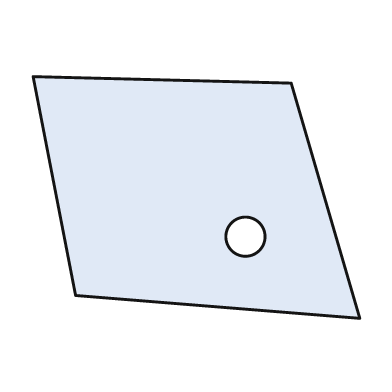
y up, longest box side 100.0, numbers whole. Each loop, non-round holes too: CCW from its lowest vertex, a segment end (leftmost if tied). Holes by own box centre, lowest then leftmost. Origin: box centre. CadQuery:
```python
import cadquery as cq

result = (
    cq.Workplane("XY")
    .moveTo(50.0, -37.0)
    .lineTo(29.0, 35.0)
    .lineTo(-50.0, 37.0)
    .lineTo(-37.0, -30.0)
    .close()
    .moveTo(15.0, -12.0)
    .circle(6.0)
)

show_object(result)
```